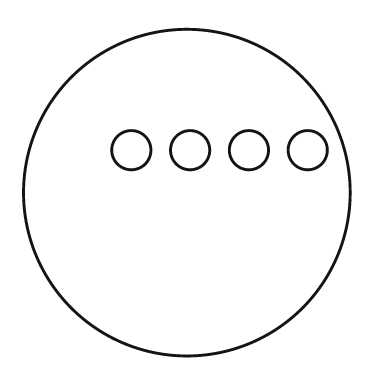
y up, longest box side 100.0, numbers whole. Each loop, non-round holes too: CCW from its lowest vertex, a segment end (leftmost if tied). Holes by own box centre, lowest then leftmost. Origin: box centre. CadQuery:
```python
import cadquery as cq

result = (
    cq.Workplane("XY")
    .moveTo(0.0, 0.0)
    .circle(50.0)
    .moveTo(-17.0, 13.0)
    .circle(6.0)
    .moveTo(1.0, 13.0)
    .circle(6.0)
    .moveTo(19.0, 13.0)
    .circle(6.0)
    .moveTo(37.0, 13.0)
    .circle(6.0)
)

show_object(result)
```